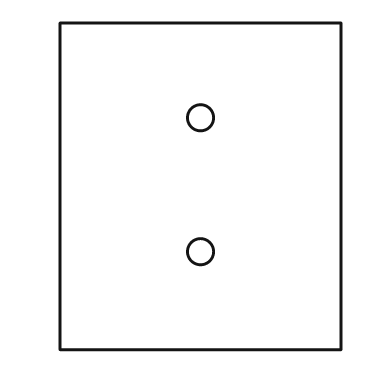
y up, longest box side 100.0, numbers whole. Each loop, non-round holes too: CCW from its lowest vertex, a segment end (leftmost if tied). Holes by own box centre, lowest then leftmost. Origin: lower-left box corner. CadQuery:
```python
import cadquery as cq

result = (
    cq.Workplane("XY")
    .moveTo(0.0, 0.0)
    .lineTo(86.0, 0.0)
    .lineTo(86.0, 100.0)
    .lineTo(0.0, 100.0)
    .close()
    .moveTo(43.0, 30.0)
    .circle(4.0)
    .moveTo(43.0, 71.0)
    .circle(4.0)
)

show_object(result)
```